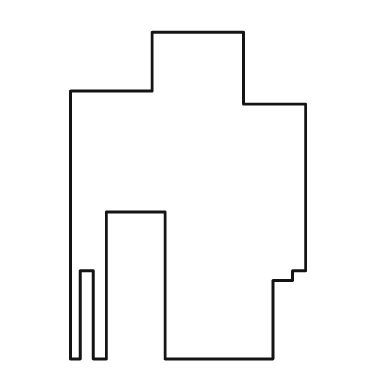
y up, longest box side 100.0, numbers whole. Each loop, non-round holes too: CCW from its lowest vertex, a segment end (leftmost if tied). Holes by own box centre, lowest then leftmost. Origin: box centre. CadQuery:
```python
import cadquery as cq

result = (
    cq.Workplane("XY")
    .moveTo(-36.0, -50.0)
    .lineTo(-33.0, -50.0)
    .lineTo(-33.0, -23.0)
    .lineTo(-29.0, -23.0)
    .lineTo(-29.0, -50.0)
    .lineTo(-25.0, -50.0)
    .lineTo(-25.0, -5.0)
    .lineTo(-7.0, -5.0)
    .lineTo(-7.0, -50.0)
    .lineTo(26.0, -50.0)
    .lineTo(26.0, -26.0)
    .lineTo(32.0, -26.0)
    .lineTo(32.0, -23.0)
    .lineTo(36.0, -23.0)
    .lineTo(36.0, 28.0)
    .lineTo(17.0, 28.0)
    .lineTo(17.0, 50.0)
    .lineTo(-11.0, 50.0)
    .lineTo(-11.0, 32.0)
    .lineTo(-36.0, 32.0)
    .close()
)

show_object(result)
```